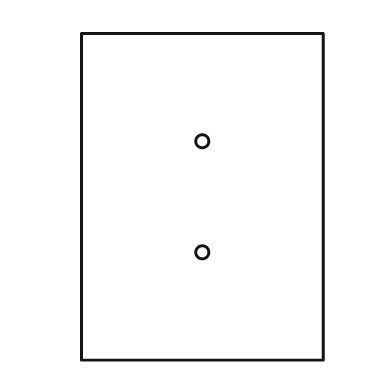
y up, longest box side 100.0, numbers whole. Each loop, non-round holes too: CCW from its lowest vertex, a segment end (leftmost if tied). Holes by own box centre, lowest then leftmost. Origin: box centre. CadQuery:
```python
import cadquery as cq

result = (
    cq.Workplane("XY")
    .moveTo(-37.0, -50.0)
    .lineTo(37.0, -50.0)
    .lineTo(37.0, 50.0)
    .lineTo(-37.0, 50.0)
    .close()
    .moveTo(0.0, -17.0)
    .circle(2.0)
    .moveTo(0.0, 17.0)
    .circle(2.0)
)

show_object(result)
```